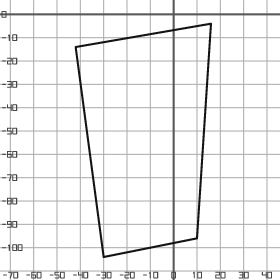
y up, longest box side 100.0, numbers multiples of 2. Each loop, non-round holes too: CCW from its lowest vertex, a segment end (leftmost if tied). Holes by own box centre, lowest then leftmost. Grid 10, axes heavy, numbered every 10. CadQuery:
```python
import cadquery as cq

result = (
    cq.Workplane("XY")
    .moveTo(-30.0, -104.0)
    .lineTo(10.0, -96.0)
    .lineTo(16.0, -4.0)
    .lineTo(-42.0, -14.0)
    .close()
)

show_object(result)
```